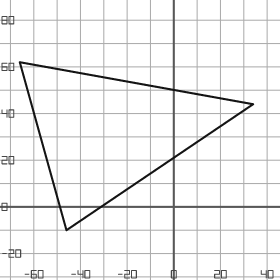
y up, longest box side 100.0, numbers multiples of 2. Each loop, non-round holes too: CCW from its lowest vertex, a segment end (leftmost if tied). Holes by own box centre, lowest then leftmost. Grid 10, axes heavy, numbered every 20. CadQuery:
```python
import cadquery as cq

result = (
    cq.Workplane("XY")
    .moveTo(-46.0, -10.0)
    .lineTo(34.0, 44.0)
    .lineTo(-66.0, 62.0)
    .close()
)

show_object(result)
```